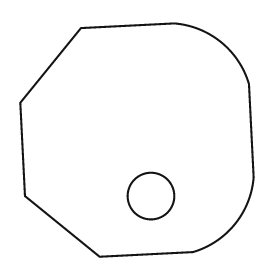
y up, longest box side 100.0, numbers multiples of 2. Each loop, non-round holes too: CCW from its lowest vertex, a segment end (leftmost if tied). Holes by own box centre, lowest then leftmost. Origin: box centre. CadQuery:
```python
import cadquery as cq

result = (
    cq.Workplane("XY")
    .moveTo(-16.0, -50.0)
    .lineTo(24.0, -48.0)
    .threePointArc((42.0, -36.0), (50.0, -16.0))
    .lineTo(48.0, 24.0)
    .threePointArc((36.0, 42.0), (16.0, 50.0))
    .lineTo(-24.0, 48.0)
    .lineTo(-50.0, 16.0)
    .lineTo(-48.0, -24.0)
    .close()
    .moveTo(6.0, -24.0)
    .circle(10.0)
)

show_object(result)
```